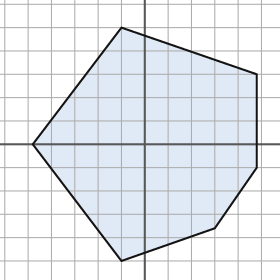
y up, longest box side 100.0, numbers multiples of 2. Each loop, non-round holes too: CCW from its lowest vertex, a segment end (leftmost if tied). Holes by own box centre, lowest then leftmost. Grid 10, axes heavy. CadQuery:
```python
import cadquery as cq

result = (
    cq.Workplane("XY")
    .moveTo(-10.0, -50.0)
    .lineTo(30.0, -36.0)
    .lineTo(48.0, -10.0)
    .lineTo(48.0, 30.0)
    .lineTo(-10.0, 50.0)
    .lineTo(-48.0, 0.0)
    .close()
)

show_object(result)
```